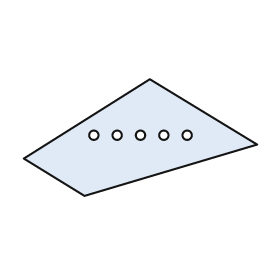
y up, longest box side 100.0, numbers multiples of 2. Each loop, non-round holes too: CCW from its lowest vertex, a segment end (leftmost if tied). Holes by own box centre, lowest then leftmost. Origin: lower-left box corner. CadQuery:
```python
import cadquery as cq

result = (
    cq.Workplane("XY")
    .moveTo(26.0, 0.0)
    .lineTo(100.0, 22.0)
    .lineTo(54.0, 50.0)
    .lineTo(0.0, 16.0)
    .close()
    .moveTo(30.0, 26.0)
    .circle(2.0)
    .moveTo(40.0, 26.0)
    .circle(2.0)
    .moveTo(50.0, 26.0)
    .circle(2.0)
    .moveTo(60.0, 26.0)
    .circle(2.0)
    .moveTo(70.0, 26.0)
    .circle(2.0)
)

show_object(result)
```